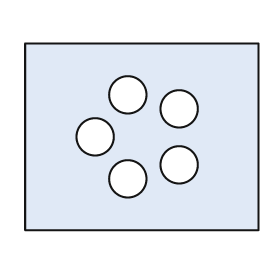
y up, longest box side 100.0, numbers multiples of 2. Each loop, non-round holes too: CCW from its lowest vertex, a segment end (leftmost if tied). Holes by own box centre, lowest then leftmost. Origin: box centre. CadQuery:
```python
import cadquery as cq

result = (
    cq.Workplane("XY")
    .moveTo(-50.0, -40.0)
    .lineTo(50.0, -40.0)
    .lineTo(50.0, 40.0)
    .lineTo(-50.0, 40.0)
    .close()
    .moveTo(-6.0, -18.0)
    .circle(8.0)
    .moveTo(16.0, -12.0)
    .circle(8.0)
    .moveTo(-20.0, 0.0)
    .circle(8.0)
    .moveTo(16.0, 12.0)
    .circle(8.0)
    .moveTo(-6.0, 18.0)
    .circle(8.0)
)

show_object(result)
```